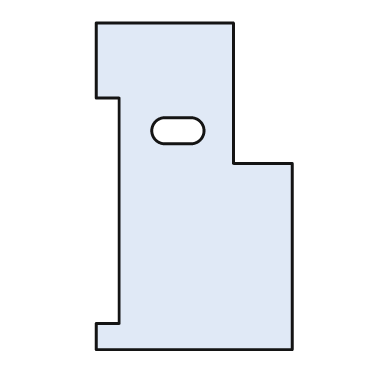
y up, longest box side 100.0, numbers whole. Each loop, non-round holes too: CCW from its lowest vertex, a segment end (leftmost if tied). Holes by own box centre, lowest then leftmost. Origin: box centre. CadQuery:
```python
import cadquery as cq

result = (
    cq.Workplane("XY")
    .moveTo(-30.0, -50.0)
    .lineTo(30.0, -50.0)
    .lineTo(30.0, 7.0)
    .lineTo(12.0, 7.0)
    .lineTo(12.0, 50.0)
    .lineTo(-30.0, 50.0)
    .lineTo(-30.0, 27.0)
    .lineTo(-23.0, 27.0)
    .lineTo(-23.0, -42.0)
    .lineTo(-30.0, -42.0)
    .close()
    .moveTo(-9.0, 13.0)
    .lineTo(-1.0, 13.0)
    .threePointArc((3.0, 17.0), (-1.0, 21.0))
    .lineTo(-9.0, 21.0)
    .threePointArc((-13.0, 17.0), (-9.0, 13.0))
    .close()
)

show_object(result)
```